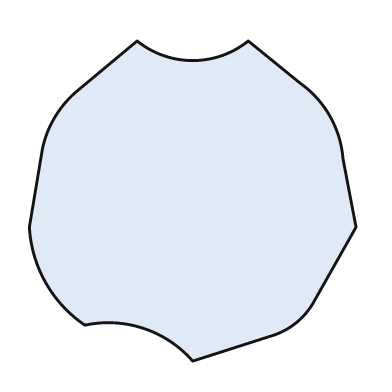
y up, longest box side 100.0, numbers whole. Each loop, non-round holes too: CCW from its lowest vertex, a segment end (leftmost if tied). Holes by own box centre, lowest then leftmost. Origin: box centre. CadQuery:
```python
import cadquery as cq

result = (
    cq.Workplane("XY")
    .moveTo(0.0, -49.0)
    .lineTo(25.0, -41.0)
    .threePointArc((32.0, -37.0), (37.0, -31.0))
    .lineTo(50.0, -8.0)
    .lineTo(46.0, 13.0)
    .threePointArc((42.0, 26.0), (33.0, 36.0))
    .lineTo(17.0, 49.0)
    .threePointArc((0.0, 43.0), (-17.0, 49.0))
    .lineTo(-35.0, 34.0)
    .threePointArc((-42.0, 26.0), (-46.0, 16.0))
    .lineTo(-50.0, -8.0)
    .threePointArc((-45.0, -25.0), (-33.0, -38.0))
    .threePointArc((-15.0, -39.0), (0.0, -49.0))
    .close()
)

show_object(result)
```